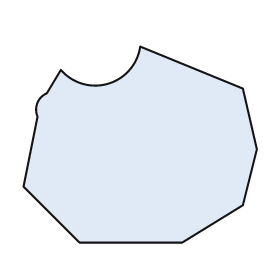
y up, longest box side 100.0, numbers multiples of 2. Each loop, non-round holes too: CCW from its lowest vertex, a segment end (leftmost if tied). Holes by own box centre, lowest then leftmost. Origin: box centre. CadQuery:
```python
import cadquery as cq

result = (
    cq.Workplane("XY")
    .moveTo(-26.0, -42.0)
    .lineTo(18.0, -42.0)
    .lineTo(44.0, -26.0)
    .lineTo(50.0, -2.0)
    .lineTo(44.0, 24.0)
    .lineTo(0.0, 42.0)
    .threePointArc((-14.0, 26.0), (-34.0, 32.0))
    .lineTo(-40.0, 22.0)
    .threePointArc((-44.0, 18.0), (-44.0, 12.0))
    .lineTo(-50.0, -18.0)
    .close()
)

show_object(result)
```